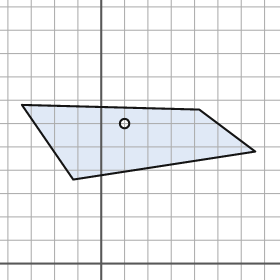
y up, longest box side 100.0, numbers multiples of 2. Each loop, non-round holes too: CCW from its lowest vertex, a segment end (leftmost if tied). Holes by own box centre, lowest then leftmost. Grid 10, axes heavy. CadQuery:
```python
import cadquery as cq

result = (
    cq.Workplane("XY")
    .moveTo(-12.0, 36.0)
    .lineTo(66.0, 48.0)
    .lineTo(42.0, 66.0)
    .lineTo(-34.0, 68.0)
    .close()
    .moveTo(10.0, 60.0)
    .circle(2.0)
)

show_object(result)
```